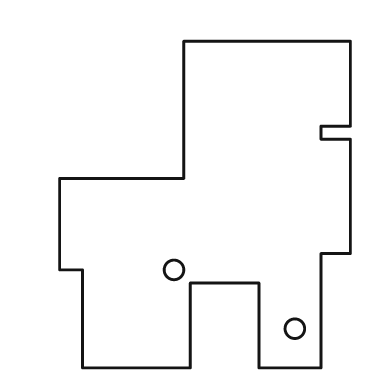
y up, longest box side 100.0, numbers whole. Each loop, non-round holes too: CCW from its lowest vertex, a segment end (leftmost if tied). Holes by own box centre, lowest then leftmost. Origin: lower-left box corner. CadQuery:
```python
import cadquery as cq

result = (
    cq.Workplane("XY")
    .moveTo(7.0, 0.0)
    .lineTo(40.0, 0.0)
    .lineTo(40.0, 26.0)
    .lineTo(61.0, 26.0)
    .lineTo(61.0, 0.0)
    .lineTo(80.0, 0.0)
    .lineTo(80.0, 35.0)
    .lineTo(89.0, 35.0)
    .lineTo(89.0, 70.0)
    .lineTo(80.0, 70.0)
    .lineTo(80.0, 74.0)
    .lineTo(89.0, 74.0)
    .lineTo(89.0, 100.0)
    .lineTo(38.0, 100.0)
    .lineTo(38.0, 58.0)
    .lineTo(0.0, 58.0)
    .lineTo(0.0, 30.0)
    .lineTo(7.0, 30.0)
    .close()
    .moveTo(72.0, 12.0)
    .circle(3.0)
    .moveTo(35.0, 30.0)
    .circle(3.0)
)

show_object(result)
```